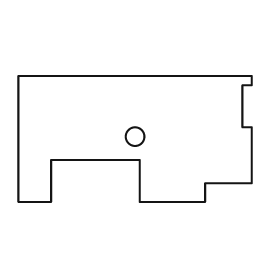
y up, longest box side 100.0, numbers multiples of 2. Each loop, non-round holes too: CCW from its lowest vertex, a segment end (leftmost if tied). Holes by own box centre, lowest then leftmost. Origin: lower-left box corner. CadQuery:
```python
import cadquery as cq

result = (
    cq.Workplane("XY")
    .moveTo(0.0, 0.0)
    .lineTo(14.0, 0.0)
    .lineTo(14.0, 18.0)
    .lineTo(52.0, 18.0)
    .lineTo(52.0, 0.0)
    .lineTo(80.0, 0.0)
    .lineTo(80.0, 8.0)
    .lineTo(100.0, 8.0)
    .lineTo(100.0, 32.0)
    .lineTo(96.0, 32.0)
    .lineTo(96.0, 50.0)
    .lineTo(100.0, 50.0)
    .lineTo(100.0, 54.0)
    .lineTo(0.0, 54.0)
    .close()
    .moveTo(50.0, 28.0)
    .circle(4.0)
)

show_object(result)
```